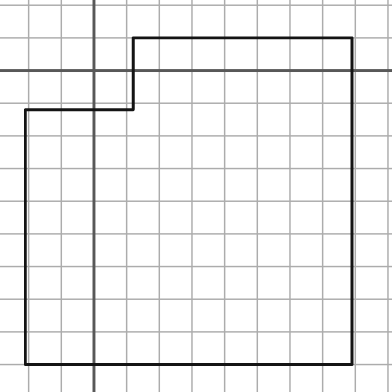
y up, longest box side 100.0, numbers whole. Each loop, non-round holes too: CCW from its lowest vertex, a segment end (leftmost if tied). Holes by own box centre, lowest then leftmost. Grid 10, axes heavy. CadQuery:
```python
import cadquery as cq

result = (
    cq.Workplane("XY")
    .moveTo(-21.0, -90.0)
    .lineTo(79.0, -90.0)
    .lineTo(79.0, 10.0)
    .lineTo(12.0, 10.0)
    .lineTo(12.0, -12.0)
    .lineTo(-21.0, -12.0)
    .close()
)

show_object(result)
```